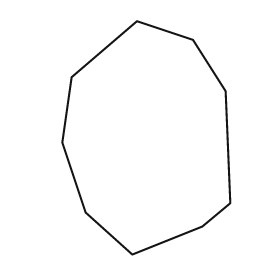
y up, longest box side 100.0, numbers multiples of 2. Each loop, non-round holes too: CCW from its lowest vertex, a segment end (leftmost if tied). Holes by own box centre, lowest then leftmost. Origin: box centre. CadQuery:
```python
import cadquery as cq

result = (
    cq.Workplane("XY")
    .moveTo(-6.0, -50.0)
    .lineTo(24.0, -38.0)
    .lineTo(36.0, -28.0)
    .lineTo(34.0, 20.0)
    .lineTo(20.0, 42.0)
    .lineTo(-4.0, 50.0)
    .lineTo(-32.0, 26.0)
    .lineTo(-36.0, -2.0)
    .lineTo(-26.0, -32.0)
    .close()
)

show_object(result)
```